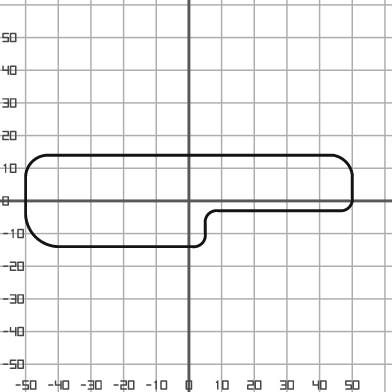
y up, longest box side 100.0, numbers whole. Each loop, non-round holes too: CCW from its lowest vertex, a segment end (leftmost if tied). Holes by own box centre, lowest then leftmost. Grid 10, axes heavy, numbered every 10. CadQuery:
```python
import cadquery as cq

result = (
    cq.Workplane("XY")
    .moveTo(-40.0, -14.0)
    .lineTo(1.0, -14.0)
    .threePointArc((4.0, -13.0), (5.0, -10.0))
    .lineTo(5.0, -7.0)
    .threePointArc((6.0, -4.0), (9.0, -3.0))
    .lineTo(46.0, -3.0)
    .threePointArc((49.0, -2.0), (50.0, 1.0))
    .lineTo(50.0, 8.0)
    .threePointArc((48.0, 12.0), (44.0, 14.0))
    .lineTo(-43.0, 14.0)
    .threePointArc((-48.0, 12.0), (-50.0, 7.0))
    .lineTo(-50.0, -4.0)
    .threePointArc((-47.0, -11.0), (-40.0, -14.0))
    .close()
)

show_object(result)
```